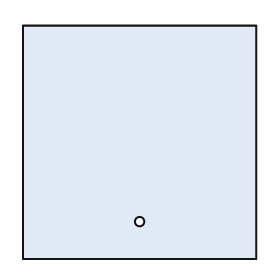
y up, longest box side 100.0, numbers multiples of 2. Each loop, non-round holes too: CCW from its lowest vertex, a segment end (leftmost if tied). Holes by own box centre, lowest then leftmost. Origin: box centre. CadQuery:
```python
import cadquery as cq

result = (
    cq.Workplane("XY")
    .moveTo(-50.0, -50.0)
    .lineTo(50.0, -50.0)
    .lineTo(50.0, 50.0)
    .lineTo(-50.0, 50.0)
    .close()
    .moveTo(0.0, -34.0)
    .circle(2.0)
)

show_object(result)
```